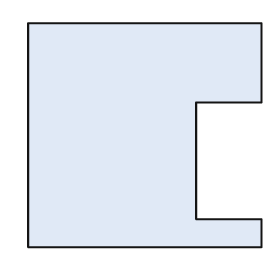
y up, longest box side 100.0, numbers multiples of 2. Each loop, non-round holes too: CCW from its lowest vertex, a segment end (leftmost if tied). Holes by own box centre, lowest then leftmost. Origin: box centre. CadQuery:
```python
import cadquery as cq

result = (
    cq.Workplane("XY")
    .moveTo(-50.0, -48.0)
    .lineTo(50.0, -48.0)
    .lineTo(50.0, -36.0)
    .lineTo(22.0, -36.0)
    .lineTo(22.0, 14.0)
    .lineTo(50.0, 14.0)
    .lineTo(50.0, 48.0)
    .lineTo(-50.0, 48.0)
    .close()
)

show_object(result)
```